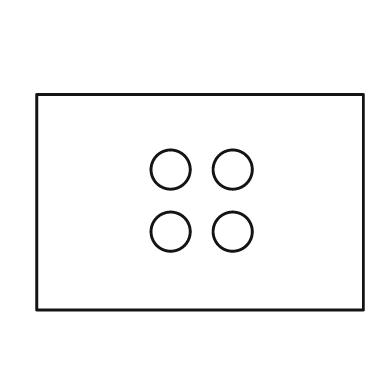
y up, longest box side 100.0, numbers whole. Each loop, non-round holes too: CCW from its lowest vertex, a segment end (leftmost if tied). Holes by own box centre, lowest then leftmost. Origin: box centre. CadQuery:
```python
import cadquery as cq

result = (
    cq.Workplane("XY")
    .moveTo(-50.0, -33.0)
    .lineTo(50.0, -33.0)
    .lineTo(50.0, 33.0)
    .lineTo(-50.0, 33.0)
    .close()
    .moveTo(-9.0, -9.0)
    .circle(6.0)
    .moveTo(10.0, -9.0)
    .circle(6.0)
    .moveTo(-9.0, 10.0)
    .circle(6.0)
    .moveTo(10.0, 10.0)
    .circle(6.0)
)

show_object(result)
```